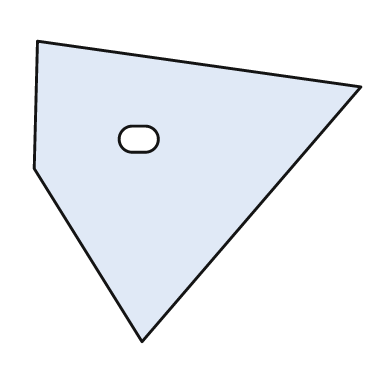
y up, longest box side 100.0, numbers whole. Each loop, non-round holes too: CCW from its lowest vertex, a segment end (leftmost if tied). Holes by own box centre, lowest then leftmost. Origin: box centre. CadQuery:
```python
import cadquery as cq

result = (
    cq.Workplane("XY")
    .moveTo(-17.0, -46.0)
    .lineTo(50.0, 32.0)
    .lineTo(-49.0, 46.0)
    .lineTo(-50.0, 7.0)
    .close()
    .moveTo(-20.0, 12.0)
    .lineTo(-16.0, 12.0)
    .threePointArc((-12.0, 16.0), (-16.0, 20.0))
    .lineTo(-20.0, 20.0)
    .threePointArc((-24.0, 16.0), (-20.0, 12.0))
    .close()
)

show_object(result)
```